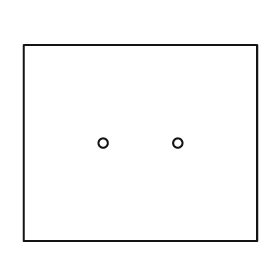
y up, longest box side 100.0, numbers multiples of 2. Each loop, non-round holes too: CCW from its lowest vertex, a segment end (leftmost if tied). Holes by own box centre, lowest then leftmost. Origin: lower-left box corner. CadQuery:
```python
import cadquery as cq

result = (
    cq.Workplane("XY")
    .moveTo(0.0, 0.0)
    .lineTo(100.0, 0.0)
    .lineTo(100.0, 84.0)
    .lineTo(0.0, 84.0)
    .close()
    .moveTo(34.0, 42.0)
    .circle(2.0)
    .moveTo(66.0, 42.0)
    .circle(2.0)
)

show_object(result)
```